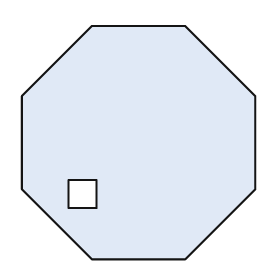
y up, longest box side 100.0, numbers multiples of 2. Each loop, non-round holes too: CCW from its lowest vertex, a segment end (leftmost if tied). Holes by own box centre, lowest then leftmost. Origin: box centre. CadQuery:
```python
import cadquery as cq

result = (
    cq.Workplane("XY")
    .moveTo(-20.0, -50.0)
    .lineTo(20.0, -50.0)
    .lineTo(50.0, -20.0)
    .lineTo(50.0, 20.0)
    .lineTo(20.0, 50.0)
    .lineTo(-20.0, 50.0)
    .lineTo(-50.0, 20.0)
    .lineTo(-50.0, -20.0)
    .close()
    .moveTo(-30.0, -28.0)
    .lineTo(-18.0, -28.0)
    .lineTo(-18.0, -16.0)
    .lineTo(-30.0, -16.0)
    .close()
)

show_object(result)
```